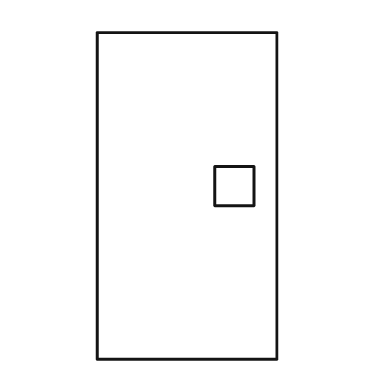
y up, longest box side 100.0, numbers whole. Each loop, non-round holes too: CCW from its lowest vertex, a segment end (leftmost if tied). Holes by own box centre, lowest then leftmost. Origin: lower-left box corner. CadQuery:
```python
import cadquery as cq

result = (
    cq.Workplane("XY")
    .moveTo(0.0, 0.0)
    .lineTo(55.0, 0.0)
    .lineTo(55.0, 100.0)
    .lineTo(0.0, 100.0)
    .close()
    .moveTo(36.0, 47.0)
    .lineTo(48.0, 47.0)
    .lineTo(48.0, 59.0)
    .lineTo(36.0, 59.0)
    .close()
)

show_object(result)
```